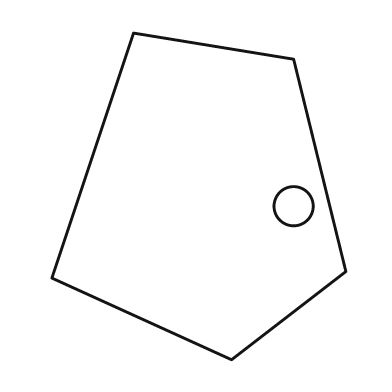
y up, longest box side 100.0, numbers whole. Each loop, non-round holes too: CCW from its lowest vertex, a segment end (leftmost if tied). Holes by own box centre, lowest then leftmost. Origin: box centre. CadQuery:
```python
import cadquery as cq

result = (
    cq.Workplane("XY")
    .moveTo(10.0, -50.0)
    .lineTo(45.0, -23.0)
    .lineTo(29.0, 42.0)
    .lineTo(-20.0, 50.0)
    .lineTo(-45.0, -25.0)
    .close()
    .moveTo(29.0, -3.0)
    .circle(6.0)
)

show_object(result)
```